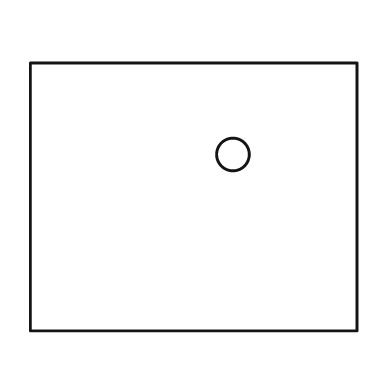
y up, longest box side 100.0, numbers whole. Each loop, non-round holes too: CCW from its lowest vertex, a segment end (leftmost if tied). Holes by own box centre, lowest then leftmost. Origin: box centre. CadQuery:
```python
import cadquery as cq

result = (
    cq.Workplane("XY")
    .moveTo(-50.0, -41.0)
    .lineTo(50.0, -41.0)
    .lineTo(50.0, 41.0)
    .lineTo(-50.0, 41.0)
    .close()
    .moveTo(12.0, 13.0)
    .circle(5.0)
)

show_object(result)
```